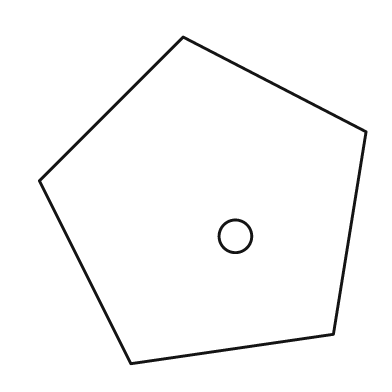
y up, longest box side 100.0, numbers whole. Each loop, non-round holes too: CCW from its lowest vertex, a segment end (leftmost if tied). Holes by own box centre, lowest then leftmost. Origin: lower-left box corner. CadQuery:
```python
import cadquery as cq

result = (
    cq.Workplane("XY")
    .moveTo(28.0, 0.0)
    .lineTo(90.0, 9.0)
    .lineTo(100.0, 71.0)
    .lineTo(44.0, 100.0)
    .lineTo(0.0, 56.0)
    .close()
    .moveTo(60.0, 39.0)
    .circle(5.0)
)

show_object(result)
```